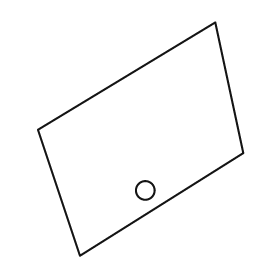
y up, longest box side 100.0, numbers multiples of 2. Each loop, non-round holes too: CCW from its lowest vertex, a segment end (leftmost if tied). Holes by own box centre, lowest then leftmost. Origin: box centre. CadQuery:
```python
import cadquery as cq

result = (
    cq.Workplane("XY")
    .moveTo(-26.0, -50.0)
    .lineTo(44.0, -6.0)
    .lineTo(32.0, 50.0)
    .lineTo(-44.0, 4.0)
    .close()
    .moveTo(2.0, -22.0)
    .circle(4.0)
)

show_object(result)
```